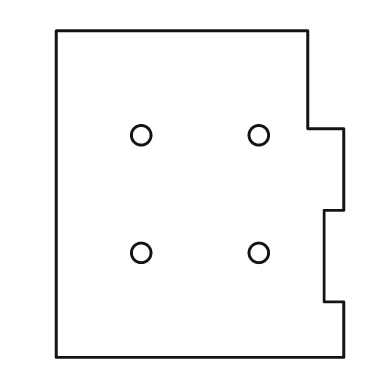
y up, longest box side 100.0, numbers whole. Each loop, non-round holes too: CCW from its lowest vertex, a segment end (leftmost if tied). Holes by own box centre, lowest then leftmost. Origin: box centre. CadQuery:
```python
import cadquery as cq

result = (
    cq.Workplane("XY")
    .moveTo(-44.0, -50.0)
    .lineTo(44.0, -50.0)
    .lineTo(44.0, -33.0)
    .lineTo(38.0, -33.0)
    .lineTo(38.0, -5.0)
    .lineTo(44.0, -5.0)
    .lineTo(44.0, 20.0)
    .lineTo(33.0, 20.0)
    .lineTo(33.0, 50.0)
    .lineTo(-44.0, 50.0)
    .close()
    .moveTo(-18.0, -18.0)
    .circle(3.0)
    .moveTo(18.0, -18.0)
    .circle(3.0)
    .moveTo(-18.0, 18.0)
    .circle(3.0)
    .moveTo(18.0, 18.0)
    .circle(3.0)
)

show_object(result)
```